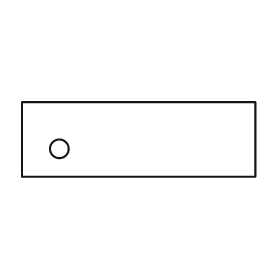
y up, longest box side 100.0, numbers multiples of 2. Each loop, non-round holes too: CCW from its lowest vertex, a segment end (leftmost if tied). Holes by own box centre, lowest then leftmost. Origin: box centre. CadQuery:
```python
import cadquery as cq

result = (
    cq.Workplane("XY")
    .moveTo(-50.0, -16.0)
    .lineTo(50.0, -16.0)
    .lineTo(50.0, 16.0)
    .lineTo(-50.0, 16.0)
    .close()
    .moveTo(-34.0, -4.0)
    .circle(4.0)
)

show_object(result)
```